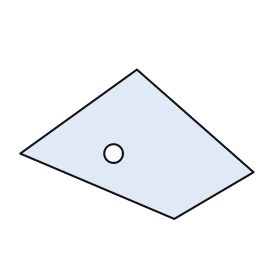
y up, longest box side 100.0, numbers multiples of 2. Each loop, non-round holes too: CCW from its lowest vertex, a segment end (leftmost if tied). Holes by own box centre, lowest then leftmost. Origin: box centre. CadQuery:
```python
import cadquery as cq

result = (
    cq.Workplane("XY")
    .moveTo(16.0, -32.0)
    .lineTo(50.0, -12.0)
    .lineTo(0.0, 32.0)
    .lineTo(-50.0, -4.0)
    .close()
    .moveTo(-10.0, -4.0)
    .circle(4.0)
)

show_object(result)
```